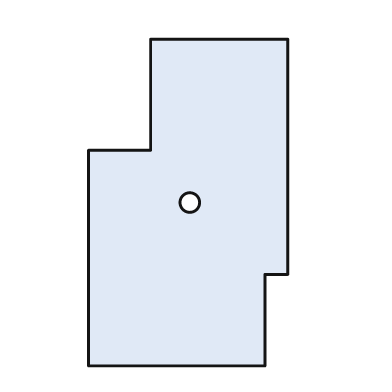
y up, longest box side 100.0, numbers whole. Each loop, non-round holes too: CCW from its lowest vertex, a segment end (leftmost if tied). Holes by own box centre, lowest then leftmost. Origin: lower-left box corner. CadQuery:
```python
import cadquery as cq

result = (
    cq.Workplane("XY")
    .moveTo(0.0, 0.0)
    .lineTo(54.0, 0.0)
    .lineTo(54.0, 28.0)
    .lineTo(61.0, 28.0)
    .lineTo(61.0, 100.0)
    .lineTo(19.0, 100.0)
    .lineTo(19.0, 66.0)
    .lineTo(0.0, 66.0)
    .close()
    .moveTo(31.0, 50.0)
    .circle(3.0)
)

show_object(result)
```